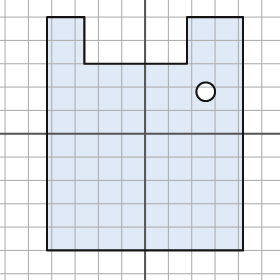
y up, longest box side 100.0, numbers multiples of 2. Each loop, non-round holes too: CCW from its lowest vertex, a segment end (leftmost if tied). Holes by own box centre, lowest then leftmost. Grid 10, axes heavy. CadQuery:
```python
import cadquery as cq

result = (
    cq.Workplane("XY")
    .moveTo(-42.0, -50.0)
    .lineTo(42.0, -50.0)
    .lineTo(42.0, 50.0)
    .lineTo(18.0, 50.0)
    .lineTo(18.0, 30.0)
    .lineTo(-26.0, 30.0)
    .lineTo(-26.0, 50.0)
    .lineTo(-42.0, 50.0)
    .close()
    .moveTo(26.0, 18.0)
    .circle(4.0)
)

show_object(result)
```